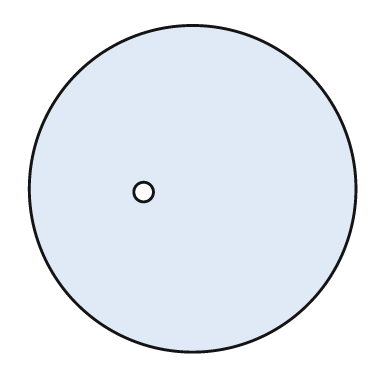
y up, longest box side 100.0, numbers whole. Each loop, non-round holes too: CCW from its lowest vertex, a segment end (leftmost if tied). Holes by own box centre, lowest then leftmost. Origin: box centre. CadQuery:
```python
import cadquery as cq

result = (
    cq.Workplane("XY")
    .moveTo(0.0, 0.0)
    .circle(50.0)
    .moveTo(-15.0, -1.0)
    .circle(3.0)
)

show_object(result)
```